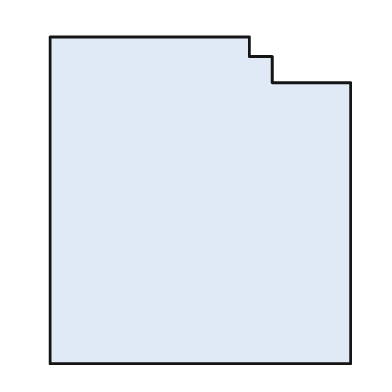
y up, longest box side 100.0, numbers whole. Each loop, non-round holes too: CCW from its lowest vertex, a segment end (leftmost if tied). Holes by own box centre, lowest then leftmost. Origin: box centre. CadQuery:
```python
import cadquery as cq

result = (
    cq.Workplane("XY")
    .moveTo(-46.0, -50.0)
    .lineTo(46.0, -50.0)
    .lineTo(46.0, 36.0)
    .lineTo(22.0, 36.0)
    .lineTo(22.0, 44.0)
    .lineTo(15.0, 44.0)
    .lineTo(15.0, 50.0)
    .lineTo(-46.0, 50.0)
    .close()
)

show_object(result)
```